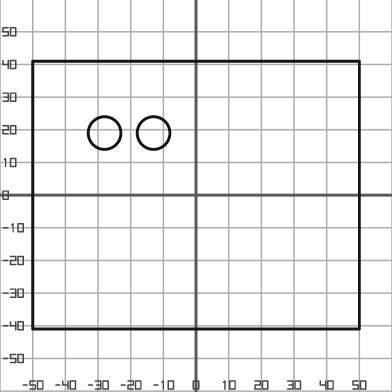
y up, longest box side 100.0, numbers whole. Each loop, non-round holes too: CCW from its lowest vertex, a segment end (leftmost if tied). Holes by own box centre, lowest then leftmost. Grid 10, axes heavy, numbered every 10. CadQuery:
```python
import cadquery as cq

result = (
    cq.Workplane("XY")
    .moveTo(-50.0, -41.0)
    .lineTo(50.0, -41.0)
    .lineTo(50.0, 41.0)
    .lineTo(-50.0, 41.0)
    .close()
    .moveTo(-28.0, 19.0)
    .circle(5.0)
    .moveTo(-13.0, 19.0)
    .circle(5.0)
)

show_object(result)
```